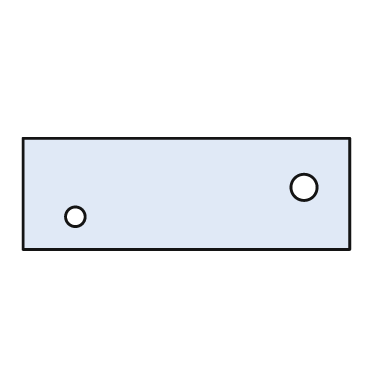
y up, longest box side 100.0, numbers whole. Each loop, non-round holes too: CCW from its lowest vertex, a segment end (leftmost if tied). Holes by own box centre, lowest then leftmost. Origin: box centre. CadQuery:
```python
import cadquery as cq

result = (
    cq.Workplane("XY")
    .moveTo(-50.0, -17.0)
    .lineTo(50.0, -17.0)
    .lineTo(50.0, 17.0)
    .lineTo(-50.0, 17.0)
    .close()
    .moveTo(-34.0, -7.0)
    .circle(3.0)
    .moveTo(36.0, 2.0)
    .circle(4.0)
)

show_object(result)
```